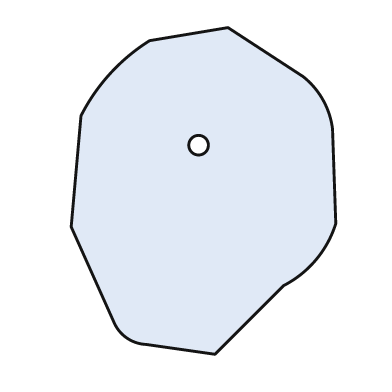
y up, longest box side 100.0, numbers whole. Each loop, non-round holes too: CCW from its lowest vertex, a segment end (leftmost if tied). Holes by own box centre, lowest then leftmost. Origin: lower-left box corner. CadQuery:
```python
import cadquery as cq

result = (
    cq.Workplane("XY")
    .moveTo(44.0, 0.0)
    .lineTo(65.0, 21.0)
    .threePointArc((75.0, 29.0), (81.0, 40.0))
    .lineTo(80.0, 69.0)
    .threePointArc((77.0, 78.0), (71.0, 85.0))
    .lineTo(48.0, 100.0)
    .lineTo(24.0, 96.0)
    .threePointArc((12.0, 86.0), (3.0, 73.0))
    .lineTo(0.0, 39.0)
    .lineTo(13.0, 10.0)
    .threePointArc((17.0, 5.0), (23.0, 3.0))
    .close()
    .moveTo(39.0, 64.0)
    .circle(3.0)
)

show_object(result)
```